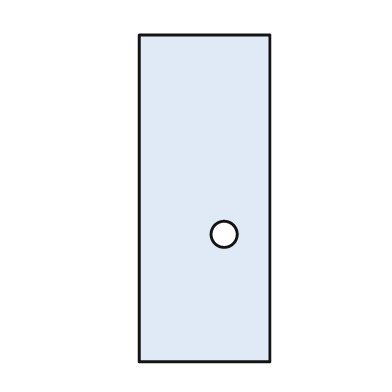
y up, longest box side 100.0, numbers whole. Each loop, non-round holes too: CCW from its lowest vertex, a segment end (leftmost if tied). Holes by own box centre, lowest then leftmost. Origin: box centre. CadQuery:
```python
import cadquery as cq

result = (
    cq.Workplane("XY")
    .moveTo(-20.0, -50.0)
    .lineTo(20.0, -50.0)
    .lineTo(20.0, 50.0)
    .lineTo(-20.0, 50.0)
    .close()
    .moveTo(6.0, -11.0)
    .circle(4.0)
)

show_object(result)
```